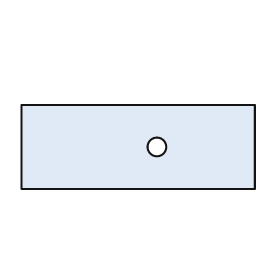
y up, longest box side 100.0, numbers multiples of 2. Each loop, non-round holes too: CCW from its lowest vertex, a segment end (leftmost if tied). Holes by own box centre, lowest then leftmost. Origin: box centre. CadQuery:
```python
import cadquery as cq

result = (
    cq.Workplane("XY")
    .moveTo(-50.0, -18.0)
    .lineTo(50.0, -18.0)
    .lineTo(50.0, 18.0)
    .lineTo(-50.0, 18.0)
    .close()
    .moveTo(8.0, 0.0)
    .circle(4.0)
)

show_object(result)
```